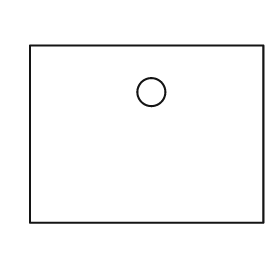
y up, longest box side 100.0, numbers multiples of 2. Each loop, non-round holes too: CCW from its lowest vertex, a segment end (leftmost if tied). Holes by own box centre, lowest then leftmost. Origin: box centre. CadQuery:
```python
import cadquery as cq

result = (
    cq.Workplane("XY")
    .moveTo(-50.0, -38.0)
    .lineTo(50.0, -38.0)
    .lineTo(50.0, 38.0)
    .lineTo(-50.0, 38.0)
    .close()
    .moveTo(2.0, 18.0)
    .circle(6.0)
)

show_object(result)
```